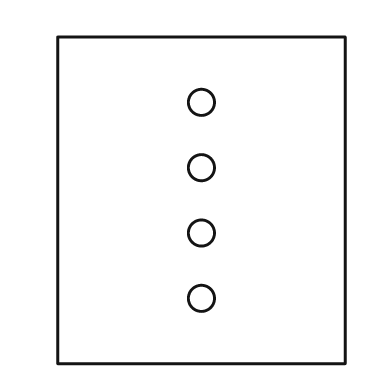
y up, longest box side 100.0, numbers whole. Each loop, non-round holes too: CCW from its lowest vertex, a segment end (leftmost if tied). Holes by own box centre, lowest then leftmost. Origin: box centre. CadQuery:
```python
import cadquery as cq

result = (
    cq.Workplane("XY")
    .moveTo(-44.0, -50.0)
    .lineTo(44.0, -50.0)
    .lineTo(44.0, 50.0)
    .lineTo(-44.0, 50.0)
    .close()
    .moveTo(0.0, -30.0)
    .circle(4.0)
    .moveTo(0.0, -10.0)
    .circle(4.0)
    .moveTo(0.0, 10.0)
    .circle(4.0)
    .moveTo(0.0, 30.0)
    .circle(4.0)
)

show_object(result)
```